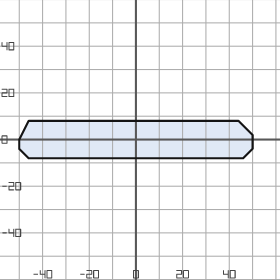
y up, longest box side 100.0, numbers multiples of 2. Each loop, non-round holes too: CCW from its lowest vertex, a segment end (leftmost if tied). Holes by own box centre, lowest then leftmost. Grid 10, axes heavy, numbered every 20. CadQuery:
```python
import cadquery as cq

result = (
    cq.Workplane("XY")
    .moveTo(-46.0, -8.0)
    .lineTo(46.0, -8.0)
    .lineTo(50.0, -4.0)
    .lineTo(50.0, 2.0)
    .lineTo(44.0, 8.0)
    .lineTo(-46.0, 8.0)
    .lineTo(-50.0, 0.0)
    .lineTo(-50.0, -4.0)
    .close()
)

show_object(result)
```